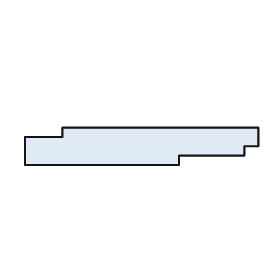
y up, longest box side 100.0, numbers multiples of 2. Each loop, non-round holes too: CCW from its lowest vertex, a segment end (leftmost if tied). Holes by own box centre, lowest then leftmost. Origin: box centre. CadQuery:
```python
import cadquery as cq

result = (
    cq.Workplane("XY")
    .moveTo(-50.0, -8.0)
    .lineTo(16.0, -8.0)
    .lineTo(16.0, -4.0)
    .lineTo(44.0, -4.0)
    .lineTo(44.0, 0.0)
    .lineTo(50.0, 0.0)
    .lineTo(50.0, 8.0)
    .lineTo(-34.0, 8.0)
    .lineTo(-34.0, 4.0)
    .lineTo(-50.0, 4.0)
    .close()
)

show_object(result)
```